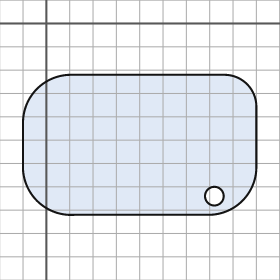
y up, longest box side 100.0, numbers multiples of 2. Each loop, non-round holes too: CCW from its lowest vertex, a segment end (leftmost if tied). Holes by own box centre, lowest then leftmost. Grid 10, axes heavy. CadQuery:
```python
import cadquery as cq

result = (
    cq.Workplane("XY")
    .moveTo(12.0, -82.0)
    .lineTo(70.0, -82.0)
    .threePointArc((84.0, -76.0), (90.0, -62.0))
    .lineTo(90.0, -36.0)
    .threePointArc((86.0, -26.0), (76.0, -22.0))
    .lineTo(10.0, -22.0)
    .threePointArc((-4.0, -28.0), (-10.0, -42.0))
    .lineTo(-10.0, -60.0)
    .threePointArc((-4.0, -76.0), (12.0, -82.0))
    .close()
    .moveTo(72.0, -74.0)
    .circle(4.0)
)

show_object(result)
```